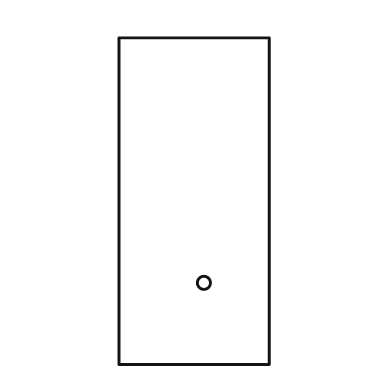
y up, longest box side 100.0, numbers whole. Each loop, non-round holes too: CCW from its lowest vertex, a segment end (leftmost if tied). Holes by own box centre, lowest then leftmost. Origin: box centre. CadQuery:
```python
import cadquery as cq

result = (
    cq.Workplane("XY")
    .moveTo(-23.0, -50.0)
    .lineTo(23.0, -50.0)
    .lineTo(23.0, 50.0)
    .lineTo(-23.0, 50.0)
    .close()
    .moveTo(3.0, -25.0)
    .circle(2.0)
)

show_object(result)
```